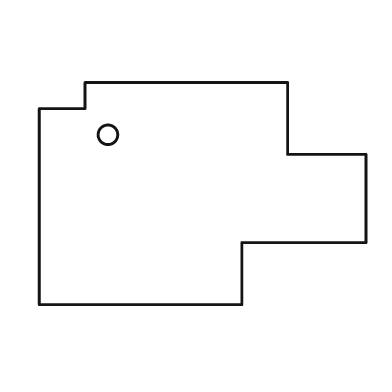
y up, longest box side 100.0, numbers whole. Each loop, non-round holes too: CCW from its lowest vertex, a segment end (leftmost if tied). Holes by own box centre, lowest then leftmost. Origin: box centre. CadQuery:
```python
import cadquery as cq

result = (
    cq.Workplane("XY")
    .moveTo(-50.0, -34.0)
    .lineTo(12.0, -34.0)
    .lineTo(12.0, -15.0)
    .lineTo(50.0, -15.0)
    .lineTo(50.0, 12.0)
    .lineTo(26.0, 12.0)
    .lineTo(26.0, 34.0)
    .lineTo(-36.0, 34.0)
    .lineTo(-36.0, 26.0)
    .lineTo(-50.0, 26.0)
    .close()
    .moveTo(-29.0, 18.0)
    .circle(3.0)
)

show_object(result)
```